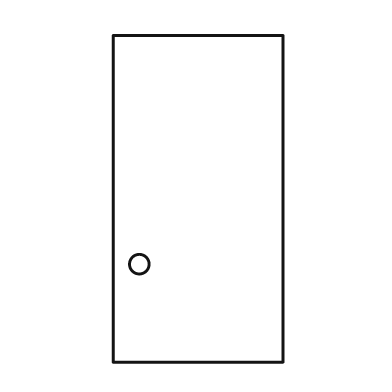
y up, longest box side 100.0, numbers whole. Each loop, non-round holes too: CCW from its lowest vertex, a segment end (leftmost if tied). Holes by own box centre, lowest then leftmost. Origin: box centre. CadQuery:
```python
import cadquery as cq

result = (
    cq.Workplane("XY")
    .moveTo(-26.0, -50.0)
    .lineTo(26.0, -50.0)
    .lineTo(26.0, 50.0)
    .lineTo(-26.0, 50.0)
    .close()
    .moveTo(-18.0, -20.0)
    .circle(3.0)
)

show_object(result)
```